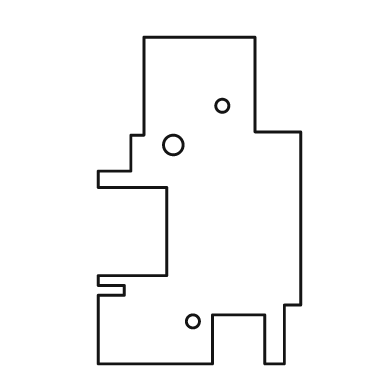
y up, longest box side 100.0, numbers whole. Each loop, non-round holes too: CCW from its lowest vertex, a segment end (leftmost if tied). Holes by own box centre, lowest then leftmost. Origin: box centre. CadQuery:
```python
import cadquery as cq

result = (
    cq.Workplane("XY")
    .moveTo(-31.0, -50.0)
    .lineTo(4.0, -50.0)
    .lineTo(4.0, -35.0)
    .lineTo(20.0, -35.0)
    .lineTo(20.0, -50.0)
    .lineTo(26.0, -50.0)
    .lineTo(26.0, -32.0)
    .lineTo(31.0, -32.0)
    .lineTo(31.0, 21.0)
    .lineTo(17.0, 21.0)
    .lineTo(17.0, 50.0)
    .lineTo(-17.0, 50.0)
    .lineTo(-17.0, 20.0)
    .lineTo(-21.0, 20.0)
    .lineTo(-21.0, 9.0)
    .lineTo(-31.0, 9.0)
    .lineTo(-31.0, 4.0)
    .lineTo(-10.0, 4.0)
    .lineTo(-10.0, -23.0)
    .lineTo(-31.0, -23.0)
    .lineTo(-31.0, -26.0)
    .lineTo(-23.0, -26.0)
    .lineTo(-23.0, -29.0)
    .lineTo(-31.0, -29.0)
    .close()
    .moveTo(-2.0, -37.0)
    .circle(2.0)
    .moveTo(-8.0, 17.0)
    .circle(3.0)
    .moveTo(7.0, 29.0)
    .circle(2.0)
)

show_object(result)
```